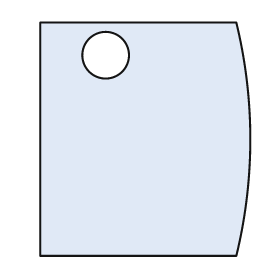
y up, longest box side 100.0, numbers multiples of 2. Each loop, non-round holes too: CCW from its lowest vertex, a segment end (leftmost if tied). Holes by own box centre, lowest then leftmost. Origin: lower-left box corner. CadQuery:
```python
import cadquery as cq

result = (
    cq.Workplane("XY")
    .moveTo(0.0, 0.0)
    .lineTo(84.0, 0.0)
    .threePointArc((90.0, 50.0), (84.0, 100.0))
    .lineTo(0.0, 100.0)
    .close()
    .moveTo(28.0, 86.0)
    .circle(10.0)
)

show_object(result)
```